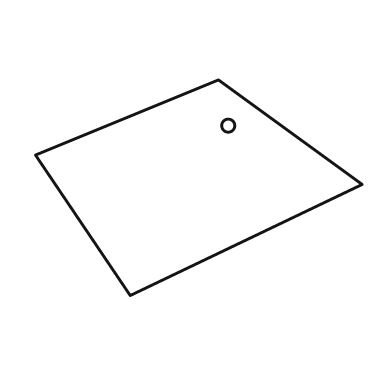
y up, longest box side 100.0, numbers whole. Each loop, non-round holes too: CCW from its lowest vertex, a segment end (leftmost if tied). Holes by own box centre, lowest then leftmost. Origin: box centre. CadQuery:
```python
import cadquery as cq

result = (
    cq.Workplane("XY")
    .moveTo(-21.0, -33.0)
    .lineTo(50.0, 1.0)
    .lineTo(6.0, 33.0)
    .lineTo(-50.0, 10.0)
    .close()
    .moveTo(9.0, 19.0)
    .circle(2.0)
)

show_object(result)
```